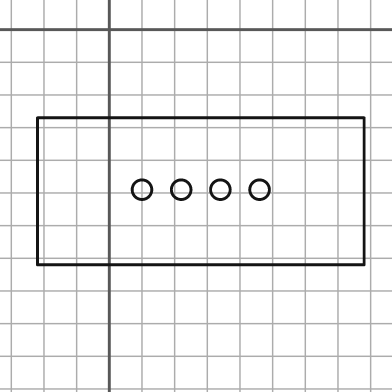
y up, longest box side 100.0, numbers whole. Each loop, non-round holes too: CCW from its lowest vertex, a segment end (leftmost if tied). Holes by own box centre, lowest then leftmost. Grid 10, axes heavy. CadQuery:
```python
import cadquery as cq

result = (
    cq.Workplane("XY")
    .moveTo(-22.0, -72.0)
    .lineTo(78.0, -72.0)
    .lineTo(78.0, -27.0)
    .lineTo(-22.0, -27.0)
    .close()
    .moveTo(10.0, -49.0)
    .circle(3.0)
    .moveTo(22.0, -49.0)
    .circle(3.0)
    .moveTo(34.0, -49.0)
    .circle(3.0)
    .moveTo(46.0, -49.0)
    .circle(3.0)
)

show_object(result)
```